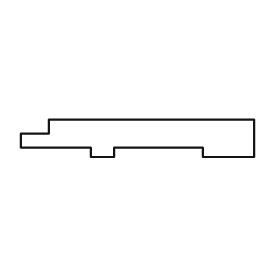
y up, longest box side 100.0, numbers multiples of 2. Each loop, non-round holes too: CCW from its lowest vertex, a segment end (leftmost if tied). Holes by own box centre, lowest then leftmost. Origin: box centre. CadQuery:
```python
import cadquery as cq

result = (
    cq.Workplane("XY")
    .moveTo(-20.0, -8.0)
    .lineTo(-10.0, -8.0)
    .lineTo(-10.0, -4.0)
    .lineTo(28.0, -4.0)
    .lineTo(28.0, -8.0)
    .lineTo(50.0, -8.0)
    .lineTo(50.0, 8.0)
    .lineTo(-38.0, 8.0)
    .lineTo(-38.0, 2.0)
    .lineTo(-50.0, 2.0)
    .lineTo(-50.0, -4.0)
    .lineTo(-20.0, -4.0)
    .close()
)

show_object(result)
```